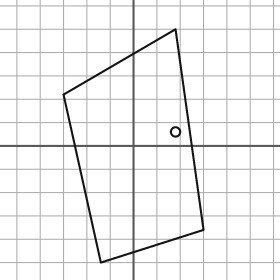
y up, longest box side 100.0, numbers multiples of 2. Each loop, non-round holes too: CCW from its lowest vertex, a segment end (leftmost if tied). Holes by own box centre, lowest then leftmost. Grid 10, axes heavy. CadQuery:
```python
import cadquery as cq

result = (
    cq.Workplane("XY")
    .moveTo(-14.0, -50.0)
    .lineTo(30.0, -36.0)
    .lineTo(18.0, 50.0)
    .lineTo(-30.0, 22.0)
    .close()
    .moveTo(18.0, 6.0)
    .circle(2.0)
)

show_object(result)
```